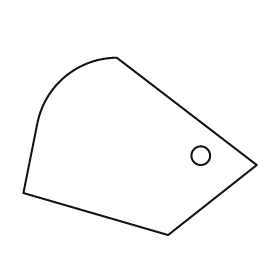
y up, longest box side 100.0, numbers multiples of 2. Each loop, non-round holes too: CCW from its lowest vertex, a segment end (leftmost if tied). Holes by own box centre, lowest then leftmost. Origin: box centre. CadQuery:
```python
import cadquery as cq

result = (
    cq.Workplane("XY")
    .moveTo(12.0, -38.0)
    .lineTo(50.0, -8.0)
    .lineTo(-10.0, 38.0)
    .threePointArc((-32.0, 30.0), (-44.0, 10.0))
    .lineTo(-50.0, -20.0)
    .close()
    .moveTo(26.0, -4.0)
    .circle(4.0)
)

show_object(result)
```